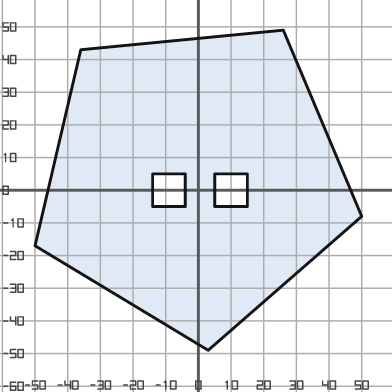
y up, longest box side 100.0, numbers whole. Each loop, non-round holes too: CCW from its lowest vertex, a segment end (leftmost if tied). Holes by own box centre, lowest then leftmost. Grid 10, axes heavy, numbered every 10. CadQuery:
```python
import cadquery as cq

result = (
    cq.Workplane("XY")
    .moveTo(3.0, -49.0)
    .lineTo(50.0, -8.0)
    .lineTo(26.0, 49.0)
    .lineTo(-36.0, 43.0)
    .lineTo(-50.0, -17.0)
    .close()
    .moveTo(-14.0, -5.0)
    .lineTo(-4.0, -5.0)
    .lineTo(-4.0, 5.0)
    .lineTo(-14.0, 5.0)
    .close()
    .moveTo(5.0, -5.0)
    .lineTo(15.0, -5.0)
    .lineTo(15.0, 5.0)
    .lineTo(5.0, 5.0)
    .close()
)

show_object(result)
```